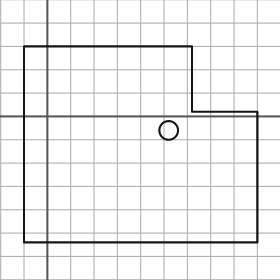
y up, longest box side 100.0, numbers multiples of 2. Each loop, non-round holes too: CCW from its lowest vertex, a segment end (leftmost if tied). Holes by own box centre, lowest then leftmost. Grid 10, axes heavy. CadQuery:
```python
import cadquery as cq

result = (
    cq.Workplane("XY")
    .moveTo(-10.0, -54.0)
    .lineTo(90.0, -54.0)
    .lineTo(90.0, 2.0)
    .lineTo(62.0, 2.0)
    .lineTo(62.0, 30.0)
    .lineTo(-10.0, 30.0)
    .close()
    .moveTo(52.0, -6.0)
    .circle(4.0)
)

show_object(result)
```